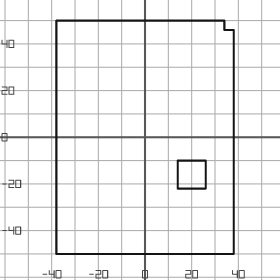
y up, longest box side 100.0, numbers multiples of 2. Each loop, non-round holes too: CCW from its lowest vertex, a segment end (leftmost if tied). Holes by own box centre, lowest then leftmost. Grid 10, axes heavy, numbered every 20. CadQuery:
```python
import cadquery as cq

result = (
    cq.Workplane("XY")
    .moveTo(-38.0, -50.0)
    .lineTo(38.0, -50.0)
    .lineTo(38.0, 46.0)
    .lineTo(34.0, 46.0)
    .lineTo(34.0, 50.0)
    .lineTo(-38.0, 50.0)
    .close()
    .moveTo(14.0, -22.0)
    .lineTo(26.0, -22.0)
    .lineTo(26.0, -10.0)
    .lineTo(14.0, -10.0)
    .close()
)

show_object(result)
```